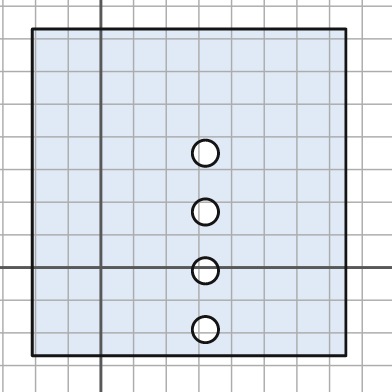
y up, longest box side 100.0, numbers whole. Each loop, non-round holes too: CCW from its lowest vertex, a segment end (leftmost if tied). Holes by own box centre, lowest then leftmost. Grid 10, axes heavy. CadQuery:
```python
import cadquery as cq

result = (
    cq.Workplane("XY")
    .moveTo(-21.0, -27.0)
    .lineTo(75.0, -27.0)
    .lineTo(75.0, 73.0)
    .lineTo(-21.0, 73.0)
    .close()
    .moveTo(32.0, -19.0)
    .circle(4.0)
    .moveTo(32.0, -1.0)
    .circle(4.0)
    .moveTo(32.0, 17.0)
    .circle(4.0)
    .moveTo(32.0, 35.0)
    .circle(4.0)
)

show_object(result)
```